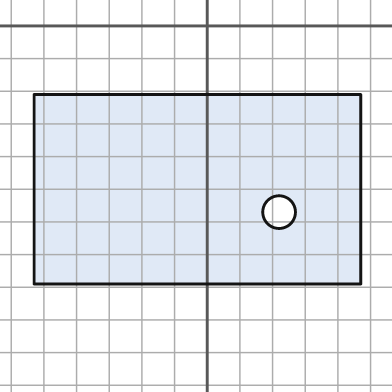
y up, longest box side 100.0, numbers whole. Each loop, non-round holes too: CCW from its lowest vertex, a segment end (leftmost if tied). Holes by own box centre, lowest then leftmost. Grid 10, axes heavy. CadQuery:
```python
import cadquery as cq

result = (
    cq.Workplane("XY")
    .moveTo(-53.0, -79.0)
    .lineTo(47.0, -79.0)
    .lineTo(47.0, -21.0)
    .lineTo(-53.0, -21.0)
    .close()
    .moveTo(22.0, -57.0)
    .circle(5.0)
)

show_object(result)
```